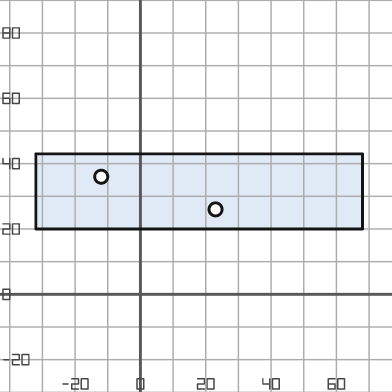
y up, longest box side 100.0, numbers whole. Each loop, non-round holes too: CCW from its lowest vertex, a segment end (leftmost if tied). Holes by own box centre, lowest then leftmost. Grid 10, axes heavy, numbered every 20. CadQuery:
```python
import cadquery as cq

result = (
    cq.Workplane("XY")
    .moveTo(-32.0, 20.0)
    .lineTo(68.0, 20.0)
    .lineTo(68.0, 43.0)
    .lineTo(-32.0, 43.0)
    .close()
    .moveTo(23.0, 26.0)
    .circle(2.0)
    .moveTo(-12.0, 36.0)
    .circle(2.0)
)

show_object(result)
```